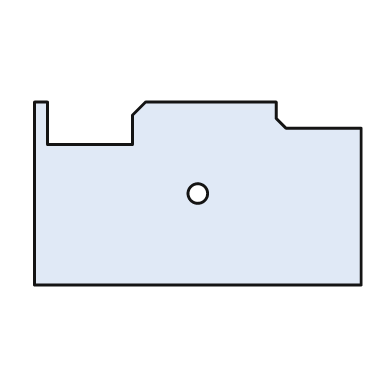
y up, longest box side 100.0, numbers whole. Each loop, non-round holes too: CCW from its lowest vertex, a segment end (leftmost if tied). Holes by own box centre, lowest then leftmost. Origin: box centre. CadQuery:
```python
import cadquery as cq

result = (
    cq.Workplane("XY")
    .moveTo(-50.0, -28.0)
    .lineTo(50.0, -28.0)
    .lineTo(50.0, 20.0)
    .lineTo(27.0, 20.0)
    .lineTo(24.0, 23.0)
    .lineTo(24.0, 28.0)
    .lineTo(-16.0, 28.0)
    .lineTo(-20.0, 24.0)
    .lineTo(-20.0, 15.0)
    .lineTo(-46.0, 15.0)
    .lineTo(-46.0, 28.0)
    .lineTo(-50.0, 28.0)
    .close()
    .moveTo(0.0, 0.0)
    .circle(3.0)
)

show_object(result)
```